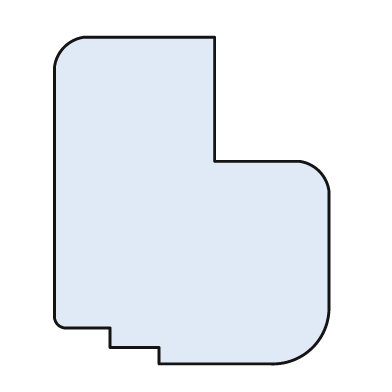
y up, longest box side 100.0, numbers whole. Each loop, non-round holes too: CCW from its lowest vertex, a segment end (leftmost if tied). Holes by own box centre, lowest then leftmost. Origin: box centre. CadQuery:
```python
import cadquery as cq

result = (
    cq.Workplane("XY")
    .moveTo(-10.0, -50.0)
    .lineTo(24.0, -50.0)
    .threePointArc((37.0, -45.0), (42.0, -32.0))
    .lineTo(42.0, 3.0)
    .threePointArc((39.0, 9.0), (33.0, 12.0))
    .lineTo(7.0, 12.0)
    .lineTo(7.0, 50.0)
    .lineTo(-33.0, 50.0)
    .threePointArc((-39.0, 47.0), (-42.0, 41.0))
    .lineTo(-42.0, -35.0)
    .threePointArc((-41.0, -38.0), (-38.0, -39.0))
    .lineTo(-25.0, -39.0)
    .lineTo(-25.0, -45.0)
    .lineTo(-10.0, -45.0)
    .close()
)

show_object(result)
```